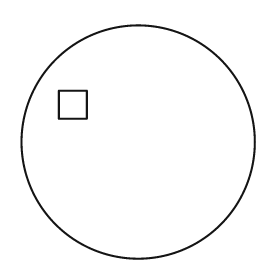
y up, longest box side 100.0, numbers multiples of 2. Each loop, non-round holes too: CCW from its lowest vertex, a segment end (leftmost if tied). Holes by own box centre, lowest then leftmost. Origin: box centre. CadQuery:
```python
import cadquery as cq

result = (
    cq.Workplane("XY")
    .moveTo(0.0, 0.0)
    .circle(50.0)
    .moveTo(-34.0, 10.0)
    .lineTo(-22.0, 10.0)
    .lineTo(-22.0, 22.0)
    .lineTo(-34.0, 22.0)
    .close()
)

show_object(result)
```